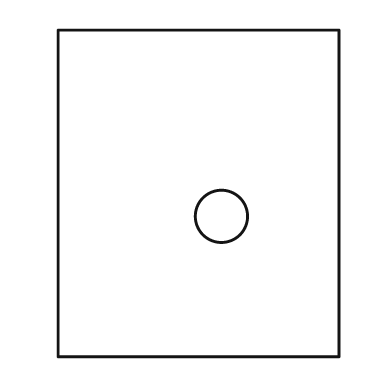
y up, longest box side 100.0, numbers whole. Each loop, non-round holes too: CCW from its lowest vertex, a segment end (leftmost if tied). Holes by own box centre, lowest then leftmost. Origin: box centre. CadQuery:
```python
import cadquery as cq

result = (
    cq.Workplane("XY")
    .moveTo(-43.0, -50.0)
    .lineTo(43.0, -50.0)
    .lineTo(43.0, 50.0)
    .lineTo(-43.0, 50.0)
    .close()
    .moveTo(7.0, -7.0)
    .circle(8.0)
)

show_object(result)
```